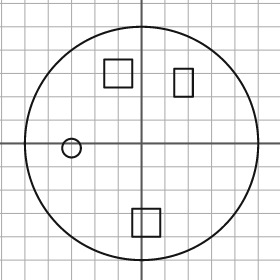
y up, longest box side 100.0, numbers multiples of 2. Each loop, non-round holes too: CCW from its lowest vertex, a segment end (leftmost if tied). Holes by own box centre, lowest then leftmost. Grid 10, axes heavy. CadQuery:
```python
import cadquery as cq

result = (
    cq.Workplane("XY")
    .moveTo(0.0, 0.0)
    .circle(50.0)
    .moveTo(-4.0, -40.0)
    .lineTo(8.0, -40.0)
    .lineTo(8.0, -28.0)
    .lineTo(-4.0, -28.0)
    .close()
    .moveTo(-30.0, -2.0)
    .circle(4.0)
    .moveTo(14.0, 20.0)
    .lineTo(22.0, 20.0)
    .lineTo(22.0, 32.0)
    .lineTo(14.0, 32.0)
    .close()
    .moveTo(-16.0, 24.0)
    .lineTo(-4.0, 24.0)
    .lineTo(-4.0, 36.0)
    .lineTo(-16.0, 36.0)
    .close()
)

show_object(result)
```